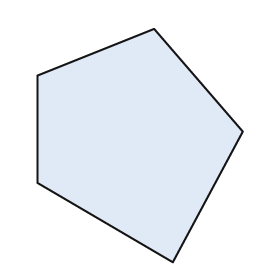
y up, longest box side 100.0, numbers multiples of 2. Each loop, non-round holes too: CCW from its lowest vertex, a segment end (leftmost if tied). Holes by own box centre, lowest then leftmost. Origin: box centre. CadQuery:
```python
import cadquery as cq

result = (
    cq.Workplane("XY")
    .moveTo(14.0, -50.0)
    .lineTo(44.0, 6.0)
    .lineTo(6.0, 50.0)
    .lineTo(-44.0, 30.0)
    .lineTo(-44.0, -16.0)
    .close()
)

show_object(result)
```